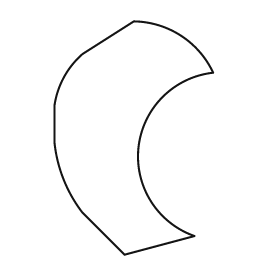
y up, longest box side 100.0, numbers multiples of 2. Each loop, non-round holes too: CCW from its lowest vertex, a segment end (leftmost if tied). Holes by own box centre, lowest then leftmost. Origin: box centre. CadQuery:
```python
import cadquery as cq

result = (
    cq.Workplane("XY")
    .moveTo(-4.0, -50.0)
    .lineTo(26.0, -42.0)
    .threePointArc((2.0, -4.0), (34.0, 28.0))
    .threePointArc((20.0, 44.0), (0.0, 50.0))
    .lineTo(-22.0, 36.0)
    .threePointArc((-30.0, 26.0), (-34.0, 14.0))
    .lineTo(-34.0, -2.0)
    .threePointArc((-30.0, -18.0), (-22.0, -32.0))
    .close()
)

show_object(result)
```